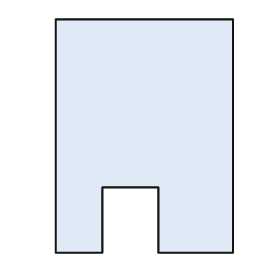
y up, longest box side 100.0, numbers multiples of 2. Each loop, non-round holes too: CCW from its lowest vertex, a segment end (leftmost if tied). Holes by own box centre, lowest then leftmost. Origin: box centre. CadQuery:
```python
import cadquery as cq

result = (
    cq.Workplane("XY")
    .moveTo(-38.0, -50.0)
    .lineTo(-18.0, -50.0)
    .lineTo(-18.0, -22.0)
    .lineTo(6.0, -22.0)
    .lineTo(6.0, -50.0)
    .lineTo(38.0, -50.0)
    .lineTo(38.0, 50.0)
    .lineTo(-38.0, 50.0)
    .close()
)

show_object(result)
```